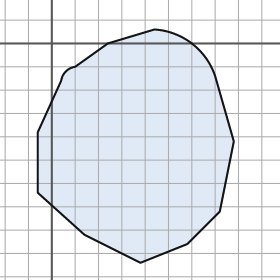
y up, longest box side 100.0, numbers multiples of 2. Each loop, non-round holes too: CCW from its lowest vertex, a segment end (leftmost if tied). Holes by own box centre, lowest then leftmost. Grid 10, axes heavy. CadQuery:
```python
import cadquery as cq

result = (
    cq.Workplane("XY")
    .moveTo(38.0, -94.0)
    .lineTo(58.0, -86.0)
    .lineTo(72.0, -72.0)
    .lineTo(78.0, -42.0)
    .lineTo(70.0, -14.0)
    .threePointArc((60.0, 0.0), (44.0, 6.0))
    .lineTo(24.0, 0.0)
    .lineTo(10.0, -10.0)
    .threePointArc((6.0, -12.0), (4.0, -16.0))
    .lineTo(-6.0, -38.0)
    .lineTo(-6.0, -64.0)
    .lineTo(14.0, -82.0)
    .close()
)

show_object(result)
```